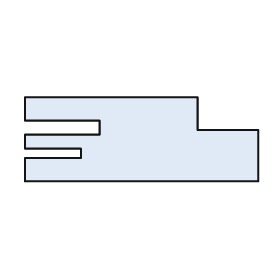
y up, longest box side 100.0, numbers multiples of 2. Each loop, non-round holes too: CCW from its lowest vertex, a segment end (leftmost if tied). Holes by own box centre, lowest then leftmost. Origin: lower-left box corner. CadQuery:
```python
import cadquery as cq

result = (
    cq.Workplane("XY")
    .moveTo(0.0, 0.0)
    .lineTo(100.0, 0.0)
    .lineTo(100.0, 22.0)
    .lineTo(74.0, 22.0)
    .lineTo(74.0, 36.0)
    .lineTo(0.0, 36.0)
    .lineTo(0.0, 26.0)
    .lineTo(32.0, 26.0)
    .lineTo(32.0, 20.0)
    .lineTo(0.0, 20.0)
    .lineTo(0.0, 14.0)
    .lineTo(24.0, 14.0)
    .lineTo(24.0, 10.0)
    .lineTo(0.0, 10.0)
    .close()
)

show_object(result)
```